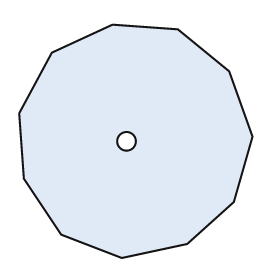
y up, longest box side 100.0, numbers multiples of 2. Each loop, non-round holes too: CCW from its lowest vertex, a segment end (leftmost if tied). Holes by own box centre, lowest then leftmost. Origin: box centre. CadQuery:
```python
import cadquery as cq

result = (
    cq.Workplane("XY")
    .moveTo(-6.0, -50.0)
    .lineTo(22.0, -44.0)
    .lineTo(42.0, -26.0)
    .lineTo(50.0, 2.0)
    .lineTo(40.0, 30.0)
    .lineTo(18.0, 48.0)
    .lineTo(-10.0, 50.0)
    .lineTo(-36.0, 38.0)
    .lineTo(-50.0, 12.0)
    .lineTo(-48.0, -16.0)
    .lineTo(-32.0, -40.0)
    .close()
    .moveTo(-4.0, 0.0)
    .circle(4.0)
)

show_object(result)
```